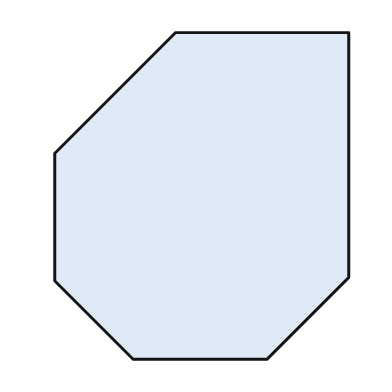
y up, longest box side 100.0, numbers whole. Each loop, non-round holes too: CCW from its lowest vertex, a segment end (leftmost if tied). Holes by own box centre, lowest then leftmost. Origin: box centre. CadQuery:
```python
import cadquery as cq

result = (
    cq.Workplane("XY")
    .moveTo(-21.0, -50.0)
    .lineTo(20.0, -50.0)
    .lineTo(45.0, -25.0)
    .lineTo(45.0, 50.0)
    .lineTo(-8.0, 50.0)
    .lineTo(-45.0, 13.0)
    .lineTo(-45.0, -26.0)
    .close()
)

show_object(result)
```